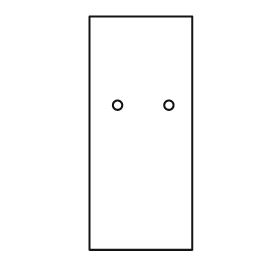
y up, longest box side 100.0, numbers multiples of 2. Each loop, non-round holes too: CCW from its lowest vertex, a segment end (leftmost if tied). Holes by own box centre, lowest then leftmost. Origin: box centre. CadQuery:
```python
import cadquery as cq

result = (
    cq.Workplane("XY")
    .moveTo(-22.0, -50.0)
    .lineTo(22.0, -50.0)
    .lineTo(22.0, 50.0)
    .lineTo(-22.0, 50.0)
    .close()
    .moveTo(-10.0, 12.0)
    .circle(2.0)
    .moveTo(12.0, 12.0)
    .circle(2.0)
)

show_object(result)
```